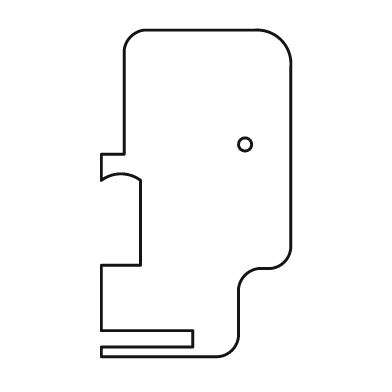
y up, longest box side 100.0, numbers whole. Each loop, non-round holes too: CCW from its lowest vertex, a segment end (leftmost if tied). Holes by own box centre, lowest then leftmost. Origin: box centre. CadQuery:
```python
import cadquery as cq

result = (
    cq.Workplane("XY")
    .moveTo(-29.0, -50.0)
    .lineTo(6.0, -50.0)
    .threePointArc((11.0, -48.0), (13.0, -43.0))
    .lineTo(13.0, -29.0)
    .threePointArc((15.0, -25.0), (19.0, -23.0))
    .lineTo(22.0, -23.0)
    .threePointArc((27.0, -21.0), (29.0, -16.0))
    .lineTo(29.0, 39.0)
    .threePointArc((26.0, 47.0), (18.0, 50.0))
    .lineTo(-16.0, 50.0)
    .threePointArc((-20.0, 48.0), (-22.0, 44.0))
    .lineTo(-22.0, 12.0)
    .lineTo(-29.0, 12.0)
    .lineTo(-29.0, 4.0)
    .threePointArc((-23.0, 6.0), (-17.0, 4.0))
    .lineTo(-17.0, -22.0)
    .lineTo(-29.0, -22.0)
    .lineTo(-29.0, -42.0)
    .lineTo(-1.0, -42.0)
    .lineTo(-1.0, -47.0)
    .lineTo(-29.0, -47.0)
    .close()
    .moveTo(15.0, 15.0)
    .circle(2.0)
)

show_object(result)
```